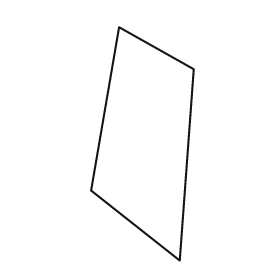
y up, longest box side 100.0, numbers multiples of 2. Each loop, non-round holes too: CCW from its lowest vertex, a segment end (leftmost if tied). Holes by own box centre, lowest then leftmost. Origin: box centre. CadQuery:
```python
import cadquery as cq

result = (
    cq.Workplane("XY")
    .moveTo(16.0, -50.0)
    .lineTo(22.0, 32.0)
    .lineTo(-10.0, 50.0)
    .lineTo(-22.0, -20.0)
    .close()
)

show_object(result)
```